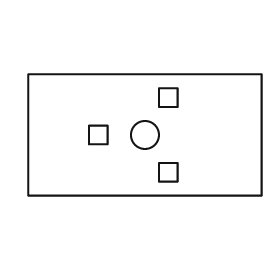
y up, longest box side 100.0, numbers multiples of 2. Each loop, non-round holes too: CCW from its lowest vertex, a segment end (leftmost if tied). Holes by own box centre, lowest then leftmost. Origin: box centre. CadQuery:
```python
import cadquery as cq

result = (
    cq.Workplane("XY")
    .moveTo(-50.0, -26.0)
    .lineTo(50.0, -26.0)
    .lineTo(50.0, 26.0)
    .lineTo(-50.0, 26.0)
    .close()
    .moveTo(6.0, -20.0)
    .lineTo(14.0, -20.0)
    .lineTo(14.0, -12.0)
    .lineTo(6.0, -12.0)
    .close()
    .moveTo(-24.0, -4.0)
    .lineTo(-16.0, -4.0)
    .lineTo(-16.0, 4.0)
    .lineTo(-24.0, 4.0)
    .close()
    .moveTo(0.0, 0.0)
    .circle(6.0)
    .moveTo(6.0, 12.0)
    .lineTo(14.0, 12.0)
    .lineTo(14.0, 20.0)
    .lineTo(6.0, 20.0)
    .close()
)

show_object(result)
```